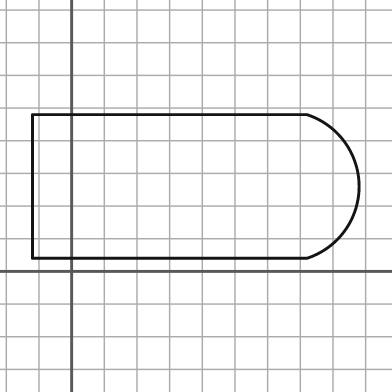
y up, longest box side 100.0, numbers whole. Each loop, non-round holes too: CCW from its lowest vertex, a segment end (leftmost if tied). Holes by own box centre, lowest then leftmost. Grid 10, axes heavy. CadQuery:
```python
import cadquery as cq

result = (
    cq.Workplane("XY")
    .moveTo(-12.0, 4.0)
    .lineTo(72.0, 4.0)
    .threePointArc((88.0, 26.0), (72.0, 48.0))
    .lineTo(-12.0, 48.0)
    .close()
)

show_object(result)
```